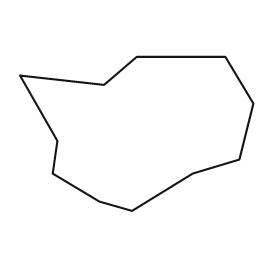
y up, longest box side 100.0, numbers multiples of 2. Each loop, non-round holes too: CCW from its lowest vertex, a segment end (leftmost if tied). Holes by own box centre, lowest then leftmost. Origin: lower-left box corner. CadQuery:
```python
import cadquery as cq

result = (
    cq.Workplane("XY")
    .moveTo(48.0, 0.0)
    .lineTo(74.0, 16.0)
    .lineTo(94.0, 22.0)
    .lineTo(100.0, 46.0)
    .lineTo(88.0, 66.0)
    .lineTo(50.0, 66.0)
    .lineTo(36.0, 54.0)
    .lineTo(0.0, 58.0)
    .lineTo(16.0, 30.0)
    .lineTo(14.0, 16.0)
    .lineTo(34.0, 4.0)
    .close()
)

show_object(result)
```